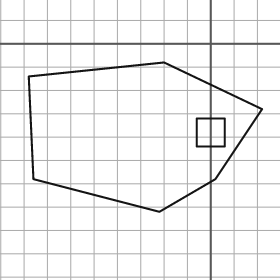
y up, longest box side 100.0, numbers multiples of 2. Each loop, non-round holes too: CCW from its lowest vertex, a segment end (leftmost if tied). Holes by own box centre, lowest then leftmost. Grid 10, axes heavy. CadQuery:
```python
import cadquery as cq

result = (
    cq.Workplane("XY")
    .moveTo(-22.0, -72.0)
    .lineTo(2.0, -58.0)
    .lineTo(22.0, -28.0)
    .lineTo(-20.0, -8.0)
    .lineTo(-78.0, -14.0)
    .lineTo(-76.0, -58.0)
    .close()
    .moveTo(-6.0, -44.0)
    .lineTo(6.0, -44.0)
    .lineTo(6.0, -32.0)
    .lineTo(-6.0, -32.0)
    .close()
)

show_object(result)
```